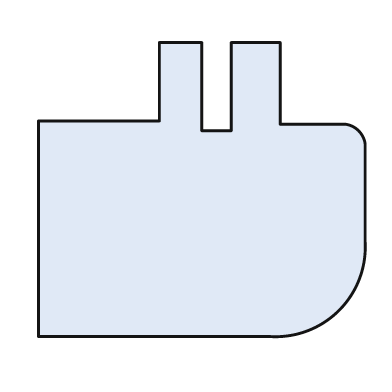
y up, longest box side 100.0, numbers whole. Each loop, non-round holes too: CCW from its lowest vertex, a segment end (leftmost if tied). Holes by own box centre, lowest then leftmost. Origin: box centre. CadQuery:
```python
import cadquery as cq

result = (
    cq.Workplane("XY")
    .moveTo(-50.0, -45.0)
    .lineTo(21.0, -45.0)
    .threePointArc((42.0, -37.0), (50.0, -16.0))
    .lineTo(50.0, 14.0)
    .threePointArc((48.0, 18.0), (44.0, 20.0))
    .lineTo(24.0, 20.0)
    .lineTo(24.0, 45.0)
    .lineTo(9.0, 45.0)
    .lineTo(9.0, 18.0)
    .lineTo(0.0, 18.0)
    .lineTo(0.0, 45.0)
    .lineTo(-13.0, 45.0)
    .lineTo(-13.0, 21.0)
    .lineTo(-50.0, 21.0)
    .close()
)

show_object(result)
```